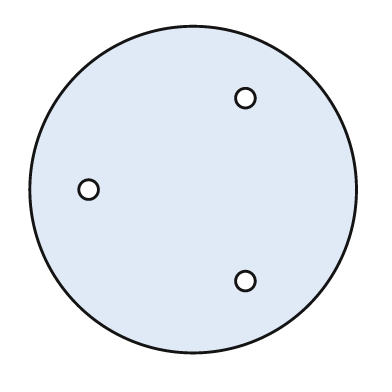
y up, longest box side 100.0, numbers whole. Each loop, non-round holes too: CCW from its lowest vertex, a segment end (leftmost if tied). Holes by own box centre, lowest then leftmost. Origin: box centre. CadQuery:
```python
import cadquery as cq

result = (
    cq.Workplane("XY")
    .moveTo(0.0, 0.0)
    .circle(50.0)
    .moveTo(16.0, -28.0)
    .circle(3.0)
    .moveTo(-32.0, 0.0)
    .circle(3.0)
    .moveTo(16.0, 28.0)
    .circle(3.0)
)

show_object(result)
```